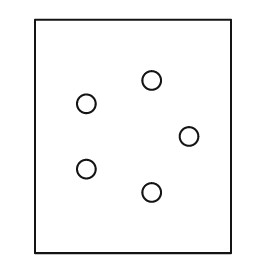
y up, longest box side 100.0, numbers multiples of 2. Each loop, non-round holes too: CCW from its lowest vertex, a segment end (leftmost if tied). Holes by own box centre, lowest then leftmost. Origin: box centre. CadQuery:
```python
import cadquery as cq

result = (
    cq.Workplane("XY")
    .moveTo(-42.0, -50.0)
    .lineTo(42.0, -50.0)
    .lineTo(42.0, 50.0)
    .lineTo(-42.0, 50.0)
    .close()
    .moveTo(8.0, -24.0)
    .circle(4.0)
    .moveTo(-20.0, -14.0)
    .circle(4.0)
    .moveTo(24.0, 0.0)
    .circle(4.0)
    .moveTo(-20.0, 14.0)
    .circle(4.0)
    .moveTo(8.0, 24.0)
    .circle(4.0)
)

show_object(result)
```